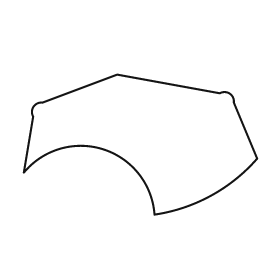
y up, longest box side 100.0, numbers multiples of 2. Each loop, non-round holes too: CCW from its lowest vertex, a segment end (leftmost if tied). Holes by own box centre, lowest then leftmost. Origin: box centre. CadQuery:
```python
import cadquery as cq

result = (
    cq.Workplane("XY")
    .moveTo(6.0, -30.0)
    .threePointArc((30.0, -22.0), (50.0, -6.0))
    .lineTo(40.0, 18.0)
    .threePointArc((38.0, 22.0), (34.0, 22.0))
    .lineTo(-10.0, 30.0)
    .lineTo(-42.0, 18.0)
    .threePointArc((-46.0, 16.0), (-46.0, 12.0))
    .lineTo(-50.0, -12.0)
    .threePointArc((-16.0, -2.0), (6.0, -30.0))
    .close()
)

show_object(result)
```